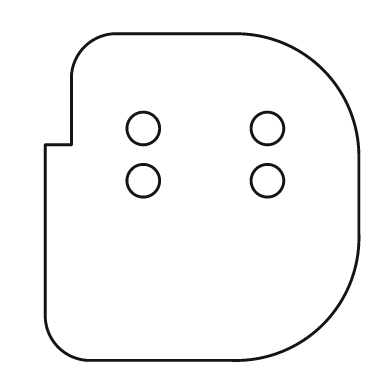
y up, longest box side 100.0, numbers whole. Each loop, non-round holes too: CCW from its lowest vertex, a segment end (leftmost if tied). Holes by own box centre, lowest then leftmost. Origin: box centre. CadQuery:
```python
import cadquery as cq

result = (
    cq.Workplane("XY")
    .moveTo(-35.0, -50.0)
    .lineTo(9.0, -50.0)
    .threePointArc((37.0, -39.0), (48.0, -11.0))
    .lineTo(48.0, 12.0)
    .threePointArc((37.0, 39.0), (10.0, 50.0))
    .lineTo(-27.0, 50.0)
    .threePointArc((-36.0, 46.0), (-40.0, 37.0))
    .lineTo(-40.0, 16.0)
    .lineTo(-48.0, 16.0)
    .lineTo(-48.0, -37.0)
    .threePointArc((-44.0, -46.0), (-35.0, -50.0))
    .close()
    .moveTo(-18.0, 5.0)
    .circle(5.0)
    .moveTo(20.0, 5.0)
    .circle(5.0)
    .moveTo(-18.0, 21.0)
    .circle(5.0)
    .moveTo(20.0, 21.0)
    .circle(5.0)
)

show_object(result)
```